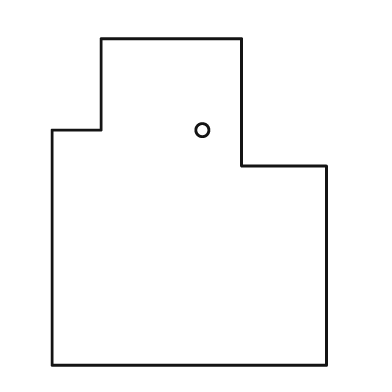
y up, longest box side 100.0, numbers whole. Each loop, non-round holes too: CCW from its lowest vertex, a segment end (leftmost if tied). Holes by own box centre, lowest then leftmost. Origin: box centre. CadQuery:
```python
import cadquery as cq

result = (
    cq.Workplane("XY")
    .moveTo(-42.0, -50.0)
    .lineTo(42.0, -50.0)
    .lineTo(42.0, 11.0)
    .lineTo(16.0, 11.0)
    .lineTo(16.0, 50.0)
    .lineTo(-27.0, 50.0)
    .lineTo(-27.0, 22.0)
    .lineTo(-42.0, 22.0)
    .close()
    .moveTo(4.0, 22.0)
    .circle(2.0)
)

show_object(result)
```